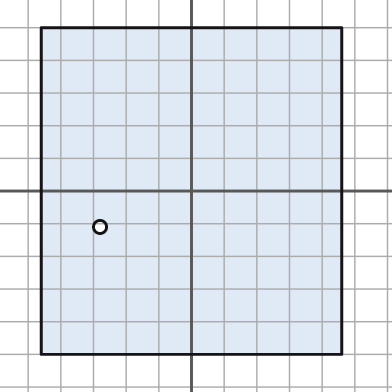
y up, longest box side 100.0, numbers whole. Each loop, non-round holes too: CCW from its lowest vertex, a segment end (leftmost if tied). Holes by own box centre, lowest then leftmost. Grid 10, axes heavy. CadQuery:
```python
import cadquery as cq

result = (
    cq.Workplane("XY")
    .moveTo(-46.0, -50.0)
    .lineTo(46.0, -50.0)
    .lineTo(46.0, 50.0)
    .lineTo(-46.0, 50.0)
    .close()
    .moveTo(-28.0, -11.0)
    .circle(2.0)
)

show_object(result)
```